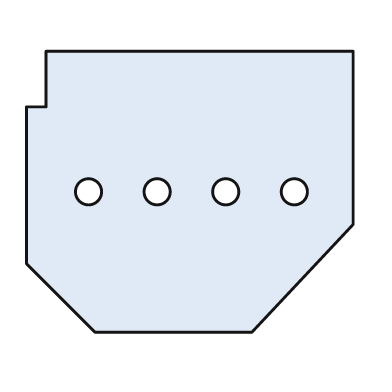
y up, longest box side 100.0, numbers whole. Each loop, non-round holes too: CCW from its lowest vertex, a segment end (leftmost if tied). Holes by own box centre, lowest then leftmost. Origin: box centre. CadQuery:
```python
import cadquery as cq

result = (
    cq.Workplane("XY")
    .moveTo(-29.0, -43.0)
    .lineTo(19.0, -43.0)
    .lineTo(50.0, -10.0)
    .lineTo(50.0, 43.0)
    .lineTo(-44.0, 43.0)
    .lineTo(-44.0, 26.0)
    .lineTo(-50.0, 26.0)
    .lineTo(-50.0, -22.0)
    .close()
    .moveTo(-31.0, 0.0)
    .circle(4.0)
    .moveTo(-10.0, 0.0)
    .circle(4.0)
    .moveTo(11.0, 0.0)
    .circle(4.0)
    .moveTo(32.0, 0.0)
    .circle(4.0)
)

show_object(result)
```